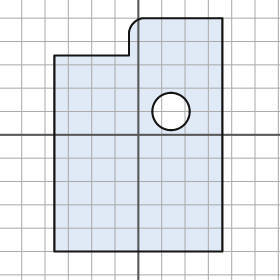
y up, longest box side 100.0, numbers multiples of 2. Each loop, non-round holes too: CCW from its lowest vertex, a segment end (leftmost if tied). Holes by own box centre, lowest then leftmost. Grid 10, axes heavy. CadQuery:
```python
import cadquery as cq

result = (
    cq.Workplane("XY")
    .moveTo(-36.0, -50.0)
    .lineTo(36.0, -50.0)
    .lineTo(36.0, 50.0)
    .lineTo(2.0, 50.0)
    .threePointArc((-2.0, 48.0), (-4.0, 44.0))
    .lineTo(-4.0, 34.0)
    .lineTo(-36.0, 34.0)
    .close()
    .moveTo(14.0, 10.0)
    .circle(8.0)
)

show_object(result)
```